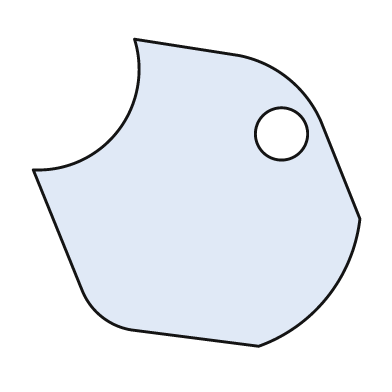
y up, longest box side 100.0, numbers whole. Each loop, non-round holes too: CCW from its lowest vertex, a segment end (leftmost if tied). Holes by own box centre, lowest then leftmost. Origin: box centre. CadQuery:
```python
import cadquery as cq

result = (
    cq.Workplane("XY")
    .moveTo(19.0, -47.0)
    .threePointArc((40.0, -32.0), (50.0, -8.0))
    .lineTo(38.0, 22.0)
    .threePointArc((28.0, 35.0), (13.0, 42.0))
    .lineTo(-19.0, 47.0)
    .threePointArc((-24.0, 19.0), (-50.0, 7.0))
    .lineTo(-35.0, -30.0)
    .threePointArc((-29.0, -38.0), (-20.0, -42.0))
    .close()
    .moveTo(26.0, 18.0)
    .circle(8.0)
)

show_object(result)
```